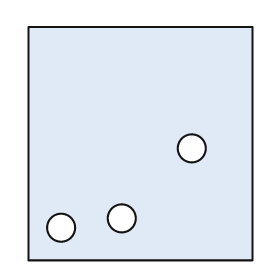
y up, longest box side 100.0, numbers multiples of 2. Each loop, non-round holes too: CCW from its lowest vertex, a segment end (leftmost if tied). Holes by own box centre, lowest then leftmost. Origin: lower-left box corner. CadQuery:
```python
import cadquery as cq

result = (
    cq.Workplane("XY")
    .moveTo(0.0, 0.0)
    .lineTo(96.0, 0.0)
    .lineTo(96.0, 100.0)
    .lineTo(0.0, 100.0)
    .close()
    .moveTo(14.0, 14.0)
    .circle(6.0)
    .moveTo(40.0, 18.0)
    .circle(6.0)
    .moveTo(70.0, 48.0)
    .circle(6.0)
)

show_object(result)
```